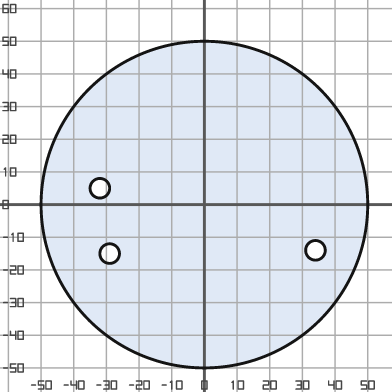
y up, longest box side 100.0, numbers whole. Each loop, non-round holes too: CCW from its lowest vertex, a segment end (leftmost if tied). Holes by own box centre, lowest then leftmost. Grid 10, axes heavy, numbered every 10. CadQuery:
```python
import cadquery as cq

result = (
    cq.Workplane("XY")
    .moveTo(0.0, 0.0)
    .circle(50.0)
    .moveTo(-29.0, -15.0)
    .circle(3.0)
    .moveTo(34.0, -14.0)
    .circle(3.0)
    .moveTo(-32.0, 5.0)
    .circle(3.0)
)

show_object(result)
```